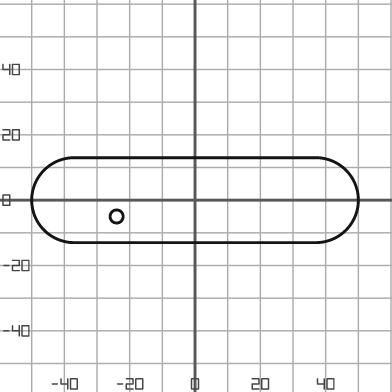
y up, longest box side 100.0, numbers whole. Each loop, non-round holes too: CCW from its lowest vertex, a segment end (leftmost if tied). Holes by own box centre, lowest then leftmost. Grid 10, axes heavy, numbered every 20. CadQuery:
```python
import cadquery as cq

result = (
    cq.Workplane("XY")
    .moveTo(-37.0, -13.0)
    .lineTo(37.0, -13.0)
    .threePointArc((50.0, 0.0), (37.0, 13.0))
    .lineTo(-37.0, 13.0)
    .threePointArc((-50.0, 0.0), (-37.0, -13.0))
    .close()
    .moveTo(-24.0, -5.0)
    .circle(2.0)
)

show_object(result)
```